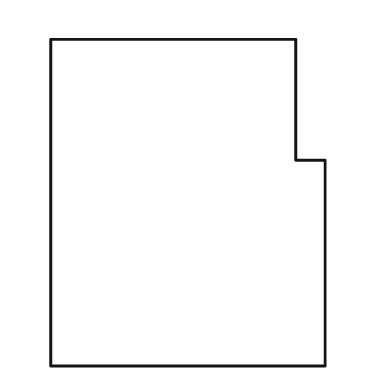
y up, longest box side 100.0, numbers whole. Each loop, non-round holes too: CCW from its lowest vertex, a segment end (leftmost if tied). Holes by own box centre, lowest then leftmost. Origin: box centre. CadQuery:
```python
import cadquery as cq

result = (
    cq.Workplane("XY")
    .moveTo(-42.0, -50.0)
    .lineTo(42.0, -50.0)
    .lineTo(42.0, 13.0)
    .lineTo(33.0, 13.0)
    .lineTo(33.0, 50.0)
    .lineTo(-42.0, 50.0)
    .close()
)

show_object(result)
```